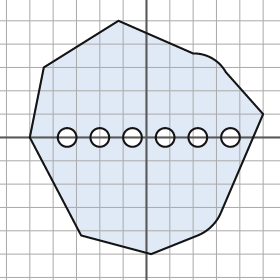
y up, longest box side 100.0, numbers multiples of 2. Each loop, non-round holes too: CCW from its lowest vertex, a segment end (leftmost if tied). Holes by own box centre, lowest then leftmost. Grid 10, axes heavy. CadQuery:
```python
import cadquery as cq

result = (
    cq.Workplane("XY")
    .moveTo(2.0, -50.0)
    .lineTo(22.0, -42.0)
    .threePointArc((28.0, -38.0), (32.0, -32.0))
    .lineTo(50.0, 10.0)
    .lineTo(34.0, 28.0)
    .threePointArc((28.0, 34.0), (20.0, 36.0))
    .lineTo(-12.0, 50.0)
    .lineTo(-44.0, 30.0)
    .lineTo(-50.0, 0.0)
    .lineTo(-28.0, -42.0)
    .close()
    .moveTo(-34.0, 0.0)
    .circle(4.0)
    .moveTo(-20.0, 0.0)
    .circle(4.0)
    .moveTo(-6.0, 0.0)
    .circle(4.0)
    .moveTo(8.0, 0.0)
    .circle(4.0)
    .moveTo(22.0, 0.0)
    .circle(4.0)
    .moveTo(36.0, 0.0)
    .circle(4.0)
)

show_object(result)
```